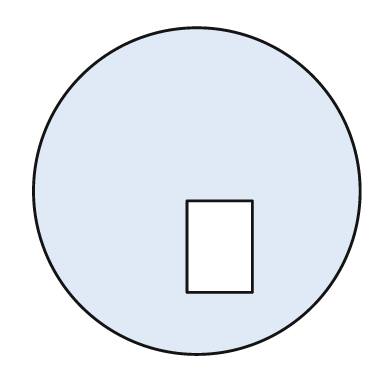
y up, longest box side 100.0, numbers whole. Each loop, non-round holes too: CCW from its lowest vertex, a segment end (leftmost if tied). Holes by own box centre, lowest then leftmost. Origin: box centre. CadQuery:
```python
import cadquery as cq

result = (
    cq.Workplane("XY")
    .moveTo(0.0, 0.0)
    .circle(50.0)
    .moveTo(-3.0, -31.0)
    .lineTo(17.0, -31.0)
    .lineTo(17.0, -3.0)
    .lineTo(-3.0, -3.0)
    .close()
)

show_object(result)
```